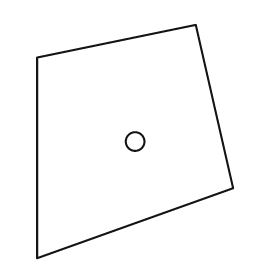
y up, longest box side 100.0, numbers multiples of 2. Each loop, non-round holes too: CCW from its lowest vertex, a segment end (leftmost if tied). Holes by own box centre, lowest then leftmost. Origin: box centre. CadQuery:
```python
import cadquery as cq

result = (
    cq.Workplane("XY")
    .moveTo(-42.0, -50.0)
    .lineTo(42.0, -20.0)
    .lineTo(26.0, 50.0)
    .lineTo(-42.0, 36.0)
    .close()
    .moveTo(0.0, 0.0)
    .circle(4.0)
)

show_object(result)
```